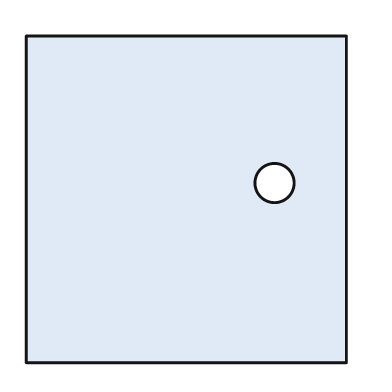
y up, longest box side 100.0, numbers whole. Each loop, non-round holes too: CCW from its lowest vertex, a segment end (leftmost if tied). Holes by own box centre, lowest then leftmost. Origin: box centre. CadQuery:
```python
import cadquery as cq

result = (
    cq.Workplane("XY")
    .moveTo(-49.0, -50.0)
    .lineTo(49.0, -50.0)
    .lineTo(49.0, 50.0)
    .lineTo(-49.0, 50.0)
    .close()
    .moveTo(27.0, 5.0)
    .circle(6.0)
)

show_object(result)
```